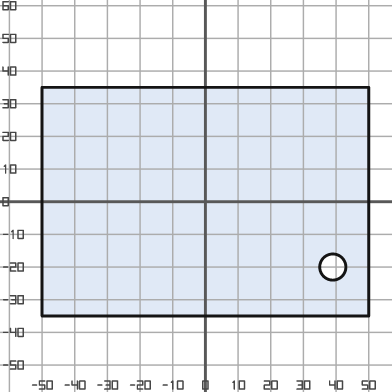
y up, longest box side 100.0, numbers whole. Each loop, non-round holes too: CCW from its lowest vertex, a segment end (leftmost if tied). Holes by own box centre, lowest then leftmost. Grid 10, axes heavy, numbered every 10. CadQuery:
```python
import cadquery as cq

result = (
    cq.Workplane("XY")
    .moveTo(-50.0, -35.0)
    .lineTo(50.0, -35.0)
    .lineTo(50.0, 35.0)
    .lineTo(-50.0, 35.0)
    .close()
    .moveTo(39.0, -20.0)
    .circle(4.0)
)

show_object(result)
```